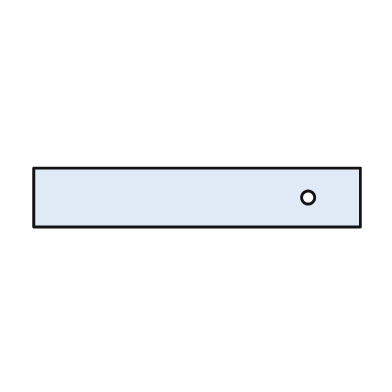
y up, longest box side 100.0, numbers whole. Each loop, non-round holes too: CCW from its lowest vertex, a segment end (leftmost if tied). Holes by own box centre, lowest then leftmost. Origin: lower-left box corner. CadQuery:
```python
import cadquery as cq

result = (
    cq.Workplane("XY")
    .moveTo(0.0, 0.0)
    .lineTo(100.0, 0.0)
    .lineTo(100.0, 18.0)
    .lineTo(0.0, 18.0)
    .close()
    .moveTo(84.0, 9.0)
    .circle(2.0)
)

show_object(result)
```